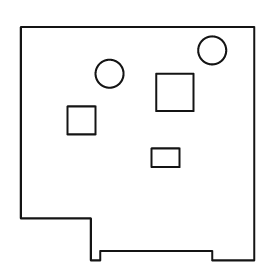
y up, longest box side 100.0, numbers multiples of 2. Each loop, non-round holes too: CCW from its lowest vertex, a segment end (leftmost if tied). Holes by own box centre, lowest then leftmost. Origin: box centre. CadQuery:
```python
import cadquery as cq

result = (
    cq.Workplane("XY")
    .moveTo(-20.0, -50.0)
    .lineTo(-16.0, -50.0)
    .lineTo(-16.0, -46.0)
    .lineTo(32.0, -46.0)
    .lineTo(32.0, -50.0)
    .lineTo(50.0, -50.0)
    .lineTo(50.0, 50.0)
    .lineTo(-50.0, 50.0)
    .lineTo(-50.0, -32.0)
    .lineTo(-20.0, -32.0)
    .close()
    .moveTo(6.0, -10.0)
    .lineTo(18.0, -10.0)
    .lineTo(18.0, -2.0)
    .lineTo(6.0, -2.0)
    .close()
    .moveTo(-30.0, 4.0)
    .lineTo(-18.0, 4.0)
    .lineTo(-18.0, 16.0)
    .lineTo(-30.0, 16.0)
    .close()
    .moveTo(8.0, 14.0)
    .lineTo(24.0, 14.0)
    .lineTo(24.0, 30.0)
    .lineTo(8.0, 30.0)
    .close()
    .moveTo(-12.0, 30.0)
    .circle(6.0)
    .moveTo(32.0, 40.0)
    .circle(6.0)
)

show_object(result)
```